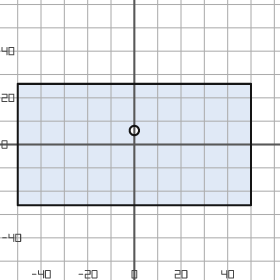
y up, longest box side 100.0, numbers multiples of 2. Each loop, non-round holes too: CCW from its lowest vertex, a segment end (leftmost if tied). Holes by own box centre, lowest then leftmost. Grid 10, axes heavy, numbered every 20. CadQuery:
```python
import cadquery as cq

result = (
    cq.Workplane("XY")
    .moveTo(-50.0, -26.0)
    .lineTo(50.0, -26.0)
    .lineTo(50.0, 26.0)
    .lineTo(-50.0, 26.0)
    .close()
    .moveTo(0.0, 6.0)
    .circle(2.0)
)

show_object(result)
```